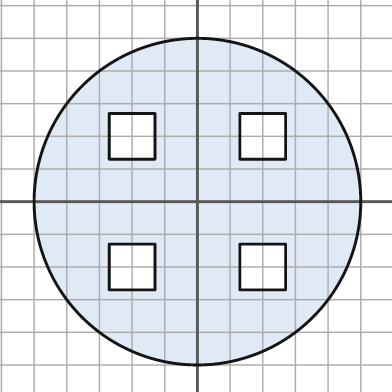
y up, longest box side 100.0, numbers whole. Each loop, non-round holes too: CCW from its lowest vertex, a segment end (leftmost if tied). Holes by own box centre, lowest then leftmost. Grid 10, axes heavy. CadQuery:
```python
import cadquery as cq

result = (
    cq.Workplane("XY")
    .moveTo(0.0, 0.0)
    .circle(50.0)
    .moveTo(-27.0, -27.0)
    .lineTo(-13.0, -27.0)
    .lineTo(-13.0, -13.0)
    .lineTo(-27.0, -13.0)
    .close()
    .moveTo(13.0, -27.0)
    .lineTo(27.0, -27.0)
    .lineTo(27.0, -13.0)
    .lineTo(13.0, -13.0)
    .close()
    .moveTo(-27.0, 13.0)
    .lineTo(-13.0, 13.0)
    .lineTo(-13.0, 27.0)
    .lineTo(-27.0, 27.0)
    .close()
    .moveTo(13.0, 13.0)
    .lineTo(27.0, 13.0)
    .lineTo(27.0, 27.0)
    .lineTo(13.0, 27.0)
    .close()
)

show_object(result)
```